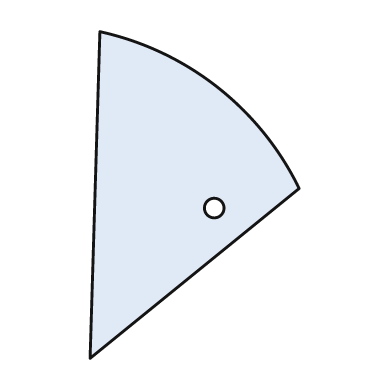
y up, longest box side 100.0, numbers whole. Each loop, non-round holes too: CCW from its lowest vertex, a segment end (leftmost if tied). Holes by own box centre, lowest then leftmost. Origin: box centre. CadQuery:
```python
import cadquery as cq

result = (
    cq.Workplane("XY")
    .moveTo(-32.0, -50.0)
    .lineTo(32.0, 2.0)
    .threePointArc((7.0, 33.0), (-29.0, 50.0))
    .close()
    .moveTo(6.0, -4.0)
    .circle(3.0)
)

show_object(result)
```